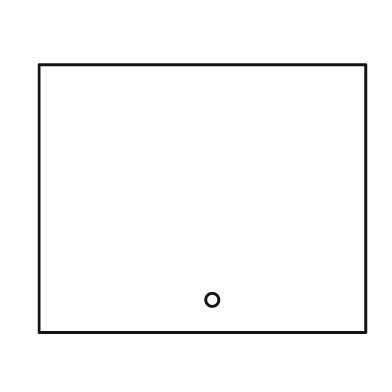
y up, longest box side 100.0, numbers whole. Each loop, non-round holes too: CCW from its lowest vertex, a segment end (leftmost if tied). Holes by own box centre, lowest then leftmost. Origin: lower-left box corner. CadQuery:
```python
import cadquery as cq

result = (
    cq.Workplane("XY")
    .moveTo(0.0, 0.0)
    .lineTo(100.0, 0.0)
    .lineTo(100.0, 82.0)
    .lineTo(0.0, 82.0)
    .close()
    .moveTo(53.0, 10.0)
    .circle(2.0)
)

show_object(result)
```